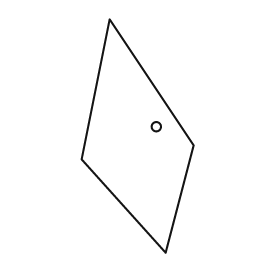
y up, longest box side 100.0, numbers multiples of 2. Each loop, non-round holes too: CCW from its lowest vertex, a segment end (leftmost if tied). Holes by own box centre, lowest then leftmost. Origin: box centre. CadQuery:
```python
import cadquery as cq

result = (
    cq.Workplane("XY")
    .moveTo(12.0, -50.0)
    .lineTo(24.0, -4.0)
    .lineTo(-12.0, 50.0)
    .lineTo(-24.0, -10.0)
    .close()
    .moveTo(8.0, 4.0)
    .circle(2.0)
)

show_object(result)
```